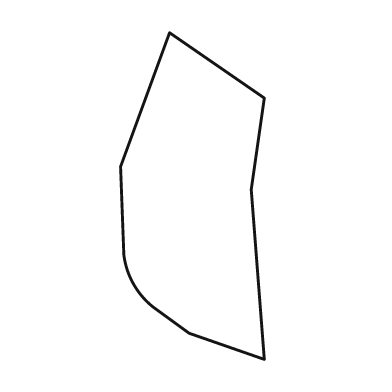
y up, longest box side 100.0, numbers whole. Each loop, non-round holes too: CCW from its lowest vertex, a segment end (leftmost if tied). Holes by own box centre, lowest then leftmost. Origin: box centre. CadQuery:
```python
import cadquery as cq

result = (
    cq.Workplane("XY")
    .moveTo(22.0, -50.0)
    .lineTo(18.0, 2.0)
    .lineTo(22.0, 30.0)
    .lineTo(-7.0, 50.0)
    .lineTo(-22.0, 9.0)
    .lineTo(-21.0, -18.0)
    .threePointArc((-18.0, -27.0), (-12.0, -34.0))
    .lineTo(-1.0, -42.0)
    .close()
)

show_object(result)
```